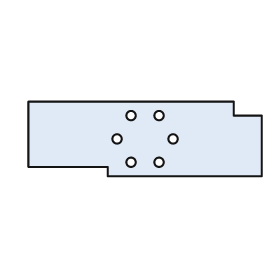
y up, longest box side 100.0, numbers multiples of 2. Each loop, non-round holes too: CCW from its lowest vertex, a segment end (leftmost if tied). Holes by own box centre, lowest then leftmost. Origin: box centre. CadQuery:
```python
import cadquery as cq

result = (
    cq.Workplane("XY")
    .moveTo(-16.0, -16.0)
    .lineTo(50.0, -16.0)
    .lineTo(50.0, 10.0)
    .lineTo(38.0, 10.0)
    .lineTo(38.0, 16.0)
    .lineTo(-50.0, 16.0)
    .lineTo(-50.0, -12.0)
    .lineTo(-16.0, -12.0)
    .close()
    .moveTo(-6.0, -10.0)
    .circle(2.0)
    .moveTo(6.0, -10.0)
    .circle(2.0)
    .moveTo(-12.0, 0.0)
    .circle(2.0)
    .moveTo(12.0, 0.0)
    .circle(2.0)
    .moveTo(-6.0, 10.0)
    .circle(2.0)
    .moveTo(6.0, 10.0)
    .circle(2.0)
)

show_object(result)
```